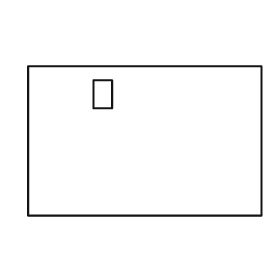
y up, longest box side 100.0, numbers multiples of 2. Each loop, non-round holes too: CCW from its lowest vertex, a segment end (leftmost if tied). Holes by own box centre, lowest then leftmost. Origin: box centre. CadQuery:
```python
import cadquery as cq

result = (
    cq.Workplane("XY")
    .moveTo(-50.0, -32.0)
    .lineTo(50.0, -32.0)
    .lineTo(50.0, 32.0)
    .lineTo(-50.0, 32.0)
    .close()
    .moveTo(-22.0, 14.0)
    .lineTo(-14.0, 14.0)
    .lineTo(-14.0, 26.0)
    .lineTo(-22.0, 26.0)
    .close()
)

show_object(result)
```